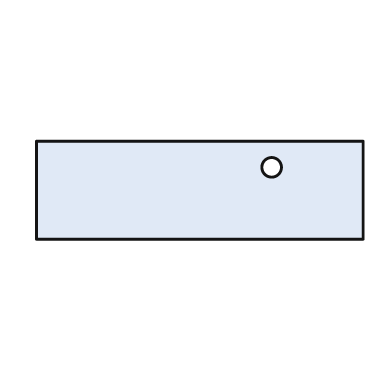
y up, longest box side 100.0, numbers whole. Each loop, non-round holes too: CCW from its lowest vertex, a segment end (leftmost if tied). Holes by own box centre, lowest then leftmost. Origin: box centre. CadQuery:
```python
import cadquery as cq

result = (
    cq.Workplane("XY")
    .moveTo(-50.0, -15.0)
    .lineTo(50.0, -15.0)
    .lineTo(50.0, 15.0)
    .lineTo(-50.0, 15.0)
    .close()
    .moveTo(22.0, 7.0)
    .circle(3.0)
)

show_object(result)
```